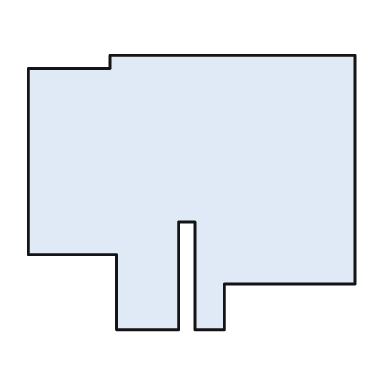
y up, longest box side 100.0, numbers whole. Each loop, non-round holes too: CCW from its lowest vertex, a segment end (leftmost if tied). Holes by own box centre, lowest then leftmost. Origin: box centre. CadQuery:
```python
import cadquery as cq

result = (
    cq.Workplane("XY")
    .moveTo(-23.0, -42.0)
    .lineTo(-4.0, -42.0)
    .lineTo(-4.0, -9.0)
    .lineTo(1.0, -9.0)
    .lineTo(1.0, -42.0)
    .lineTo(10.0, -42.0)
    .lineTo(10.0, -28.0)
    .lineTo(50.0, -28.0)
    .lineTo(50.0, 42.0)
    .lineTo(-25.0, 42.0)
    .lineTo(-25.0, 38.0)
    .lineTo(-50.0, 38.0)
    .lineTo(-50.0, -19.0)
    .lineTo(-23.0, -19.0)
    .close()
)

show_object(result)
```